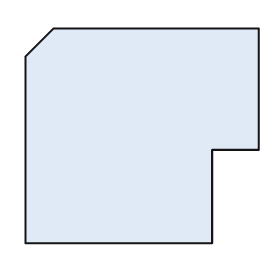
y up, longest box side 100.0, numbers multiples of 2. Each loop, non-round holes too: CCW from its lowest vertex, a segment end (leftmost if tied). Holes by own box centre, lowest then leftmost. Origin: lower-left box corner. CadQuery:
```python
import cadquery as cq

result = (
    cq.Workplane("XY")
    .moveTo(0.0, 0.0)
    .lineTo(80.0, 0.0)
    .lineTo(80.0, 40.0)
    .lineTo(100.0, 40.0)
    .lineTo(100.0, 92.0)
    .lineTo(12.0, 92.0)
    .lineTo(0.0, 80.0)
    .close()
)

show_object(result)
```